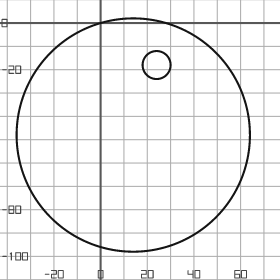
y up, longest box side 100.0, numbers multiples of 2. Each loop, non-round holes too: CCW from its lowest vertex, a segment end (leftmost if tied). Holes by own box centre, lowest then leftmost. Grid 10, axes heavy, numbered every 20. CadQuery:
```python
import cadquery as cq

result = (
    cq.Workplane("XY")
    .moveTo(14.0, -48.0)
    .circle(50.0)
    .moveTo(24.0, -18.0)
    .circle(6.0)
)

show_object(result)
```